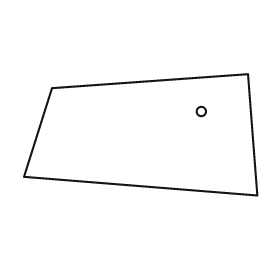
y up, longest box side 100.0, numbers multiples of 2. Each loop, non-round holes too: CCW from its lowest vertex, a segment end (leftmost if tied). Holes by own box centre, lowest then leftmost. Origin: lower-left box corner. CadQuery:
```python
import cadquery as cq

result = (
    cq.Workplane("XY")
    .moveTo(100.0, 0.0)
    .lineTo(96.0, 52.0)
    .lineTo(12.0, 46.0)
    .lineTo(0.0, 8.0)
    .close()
    .moveTo(76.0, 36.0)
    .circle(2.0)
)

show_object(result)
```